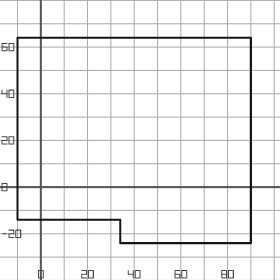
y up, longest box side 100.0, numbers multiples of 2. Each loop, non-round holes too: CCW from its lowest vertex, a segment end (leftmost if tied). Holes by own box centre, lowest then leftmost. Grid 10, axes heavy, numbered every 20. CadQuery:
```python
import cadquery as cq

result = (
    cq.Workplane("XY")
    .moveTo(34.0, -24.0)
    .lineTo(90.0, -24.0)
    .lineTo(90.0, 64.0)
    .lineTo(-10.0, 64.0)
    .lineTo(-10.0, -14.0)
    .lineTo(34.0, -14.0)
    .close()
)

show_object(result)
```